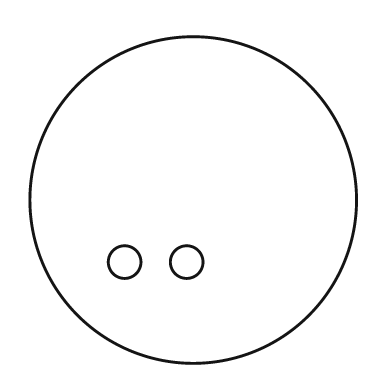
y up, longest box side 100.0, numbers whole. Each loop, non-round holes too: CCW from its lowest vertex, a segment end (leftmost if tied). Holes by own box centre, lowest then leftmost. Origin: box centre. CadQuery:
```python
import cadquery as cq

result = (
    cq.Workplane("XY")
    .moveTo(0.0, 0.0)
    .circle(50.0)
    .moveTo(-21.0, -19.0)
    .circle(5.0)
    .moveTo(-2.0, -19.0)
    .circle(5.0)
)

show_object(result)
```